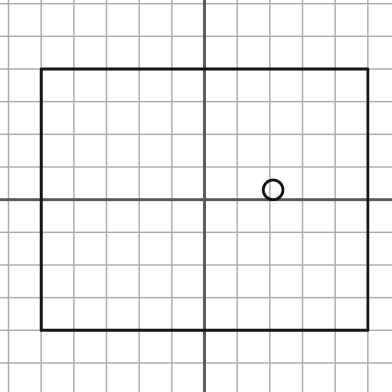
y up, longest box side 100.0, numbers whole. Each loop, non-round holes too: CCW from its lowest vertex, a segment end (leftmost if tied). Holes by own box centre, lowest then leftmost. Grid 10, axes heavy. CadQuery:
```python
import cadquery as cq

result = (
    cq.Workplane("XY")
    .moveTo(-50.0, -40.0)
    .lineTo(50.0, -40.0)
    .lineTo(50.0, 40.0)
    .lineTo(-50.0, 40.0)
    .close()
    .moveTo(21.0, 3.0)
    .circle(3.0)
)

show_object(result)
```